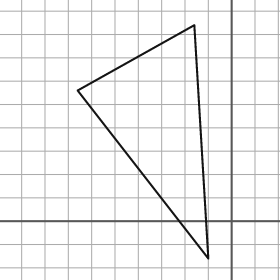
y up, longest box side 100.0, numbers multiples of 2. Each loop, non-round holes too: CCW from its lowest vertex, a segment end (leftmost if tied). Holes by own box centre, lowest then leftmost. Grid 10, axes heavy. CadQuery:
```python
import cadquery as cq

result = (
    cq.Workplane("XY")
    .moveTo(-10.0, -16.0)
    .lineTo(-16.0, 84.0)
    .lineTo(-66.0, 56.0)
    .close()
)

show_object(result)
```